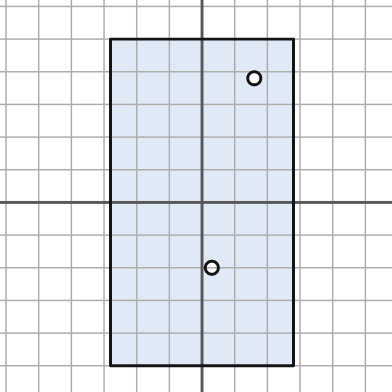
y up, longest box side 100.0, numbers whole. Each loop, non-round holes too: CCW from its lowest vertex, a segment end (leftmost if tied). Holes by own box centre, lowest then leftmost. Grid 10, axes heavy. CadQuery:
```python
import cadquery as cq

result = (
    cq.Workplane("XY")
    .moveTo(-28.0, -50.0)
    .lineTo(28.0, -50.0)
    .lineTo(28.0, 50.0)
    .lineTo(-28.0, 50.0)
    .close()
    .moveTo(3.0, -20.0)
    .circle(2.0)
    .moveTo(16.0, 38.0)
    .circle(2.0)
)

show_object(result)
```